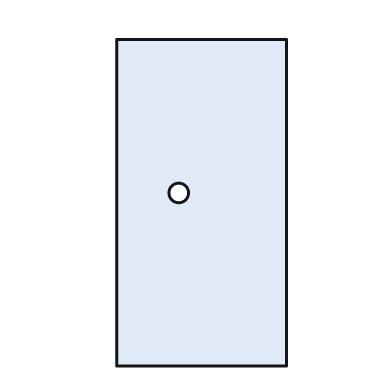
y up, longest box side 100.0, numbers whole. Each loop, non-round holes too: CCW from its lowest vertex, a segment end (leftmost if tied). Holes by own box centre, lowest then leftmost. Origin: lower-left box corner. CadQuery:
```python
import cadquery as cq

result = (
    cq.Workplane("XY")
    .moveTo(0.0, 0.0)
    .lineTo(52.0, 0.0)
    .lineTo(52.0, 100.0)
    .lineTo(0.0, 100.0)
    .close()
    .moveTo(19.0, 53.0)
    .circle(3.0)
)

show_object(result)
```